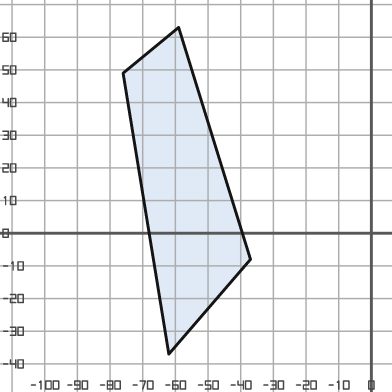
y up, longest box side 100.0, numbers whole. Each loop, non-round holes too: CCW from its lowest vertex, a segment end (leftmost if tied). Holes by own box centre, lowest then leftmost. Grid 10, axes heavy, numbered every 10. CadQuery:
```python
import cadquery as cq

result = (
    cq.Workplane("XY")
    .moveTo(-62.0, -37.0)
    .lineTo(-37.0, -8.0)
    .lineTo(-59.0, 63.0)
    .lineTo(-76.0, 49.0)
    .close()
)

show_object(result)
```